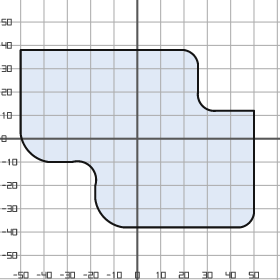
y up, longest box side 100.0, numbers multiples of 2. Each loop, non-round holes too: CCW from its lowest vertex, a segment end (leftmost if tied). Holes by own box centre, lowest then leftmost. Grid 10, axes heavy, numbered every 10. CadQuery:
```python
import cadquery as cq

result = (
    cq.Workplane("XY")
    .moveTo(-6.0, -38.0)
    .lineTo(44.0, -38.0)
    .threePointArc((48.0, -36.0), (50.0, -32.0))
    .lineTo(50.0, 12.0)
    .lineTo(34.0, 12.0)
    .threePointArc((28.0, 14.0), (26.0, 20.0))
    .lineTo(26.0, 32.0)
    .threePointArc((24.0, 36.0), (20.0, 38.0))
    .lineTo(-50.0, 38.0)
    .lineTo(-50.0, 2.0)
    .threePointArc((-46.0, -6.0), (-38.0, -10.0))
    .lineTo(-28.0, -10.0)
    .threePointArc((-20.0, -12.0), (-18.0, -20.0))
    .lineTo(-18.0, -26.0)
    .threePointArc((-14.0, -34.0), (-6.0, -38.0))
    .close()
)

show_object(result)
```